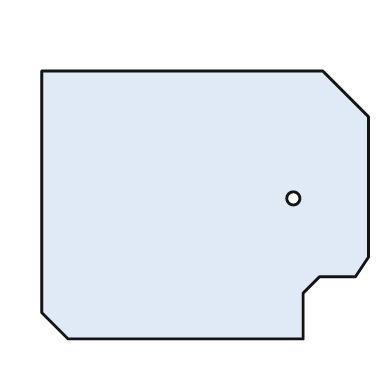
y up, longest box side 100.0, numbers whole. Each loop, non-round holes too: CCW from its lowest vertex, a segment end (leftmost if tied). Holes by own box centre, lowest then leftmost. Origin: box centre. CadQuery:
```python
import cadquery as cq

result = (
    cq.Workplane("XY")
    .moveTo(-42.0, -41.0)
    .lineTo(30.0, -41.0)
    .lineTo(30.0, -27.0)
    .lineTo(35.0, -22.0)
    .lineTo(46.0, -22.0)
    .lineTo(50.0, -16.0)
    .lineTo(50.0, 27.0)
    .lineTo(36.0, 41.0)
    .lineTo(-50.0, 41.0)
    .lineTo(-50.0, -33.0)
    .close()
    .moveTo(27.0, 2.0)
    .circle(2.0)
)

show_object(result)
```